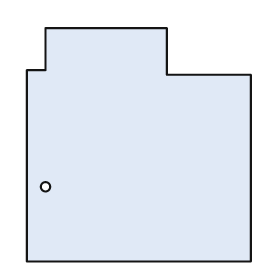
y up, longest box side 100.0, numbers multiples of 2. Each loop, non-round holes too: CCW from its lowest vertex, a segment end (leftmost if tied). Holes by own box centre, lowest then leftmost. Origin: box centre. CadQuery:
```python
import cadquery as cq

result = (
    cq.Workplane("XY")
    .moveTo(-48.0, -50.0)
    .lineTo(48.0, -50.0)
    .lineTo(48.0, 30.0)
    .lineTo(12.0, 30.0)
    .lineTo(12.0, 50.0)
    .lineTo(-40.0, 50.0)
    .lineTo(-40.0, 32.0)
    .lineTo(-48.0, 32.0)
    .close()
    .moveTo(-40.0, -18.0)
    .circle(2.0)
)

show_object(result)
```